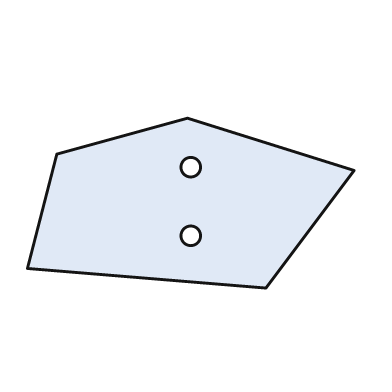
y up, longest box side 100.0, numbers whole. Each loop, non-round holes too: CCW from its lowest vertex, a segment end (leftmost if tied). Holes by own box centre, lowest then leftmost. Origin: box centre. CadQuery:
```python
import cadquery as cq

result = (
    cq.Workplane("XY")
    .moveTo(23.0, -26.0)
    .lineTo(50.0, 10.0)
    .lineTo(-1.0, 26.0)
    .lineTo(-41.0, 15.0)
    .lineTo(-50.0, -20.0)
    .close()
    .moveTo(0.0, -10.0)
    .circle(3.0)
    .moveTo(0.0, 11.0)
    .circle(3.0)
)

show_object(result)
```